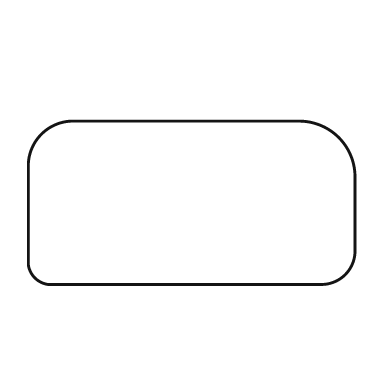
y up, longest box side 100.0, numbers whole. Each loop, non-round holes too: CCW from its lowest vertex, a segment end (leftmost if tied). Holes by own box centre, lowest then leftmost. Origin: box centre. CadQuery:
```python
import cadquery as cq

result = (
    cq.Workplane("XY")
    .moveTo(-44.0, -25.0)
    .lineTo(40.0, -25.0)
    .threePointArc((47.0, -22.0), (50.0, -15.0))
    .lineTo(50.0, 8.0)
    .threePointArc((45.0, 20.0), (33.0, 25.0))
    .lineTo(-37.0, 25.0)
    .threePointArc((-46.0, 21.0), (-50.0, 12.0))
    .lineTo(-50.0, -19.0)
    .threePointArc((-48.0, -23.0), (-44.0, -25.0))
    .close()
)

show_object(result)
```